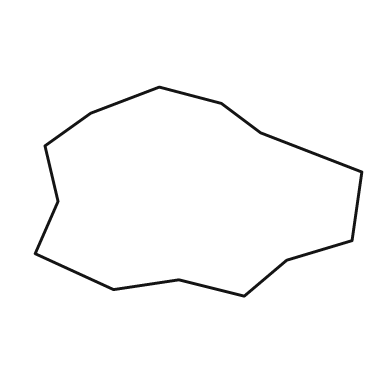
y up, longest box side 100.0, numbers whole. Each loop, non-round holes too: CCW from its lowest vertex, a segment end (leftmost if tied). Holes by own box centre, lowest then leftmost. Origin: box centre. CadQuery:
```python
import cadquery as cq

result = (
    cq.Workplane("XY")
    .moveTo(14.0, -32.0)
    .lineTo(27.0, -21.0)
    .lineTo(47.0, -15.0)
    .lineTo(50.0, 6.0)
    .lineTo(19.0, 18.0)
    .lineTo(7.0, 27.0)
    .lineTo(-12.0, 32.0)
    .lineTo(-33.0, 24.0)
    .lineTo(-47.0, 14.0)
    .lineTo(-43.0, -3.0)
    .lineTo(-50.0, -19.0)
    .lineTo(-26.0, -30.0)
    .lineTo(-6.0, -27.0)
    .close()
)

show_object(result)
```